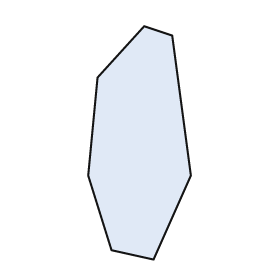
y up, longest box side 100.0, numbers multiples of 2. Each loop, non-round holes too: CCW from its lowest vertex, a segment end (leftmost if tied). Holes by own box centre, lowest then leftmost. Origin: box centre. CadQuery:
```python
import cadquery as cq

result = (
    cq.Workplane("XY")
    .moveTo(6.0, -50.0)
    .lineTo(22.0, -14.0)
    .lineTo(14.0, 46.0)
    .lineTo(2.0, 50.0)
    .lineTo(-18.0, 28.0)
    .lineTo(-22.0, -14.0)
    .lineTo(-12.0, -46.0)
    .close()
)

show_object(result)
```